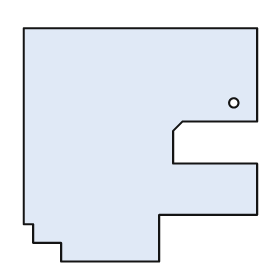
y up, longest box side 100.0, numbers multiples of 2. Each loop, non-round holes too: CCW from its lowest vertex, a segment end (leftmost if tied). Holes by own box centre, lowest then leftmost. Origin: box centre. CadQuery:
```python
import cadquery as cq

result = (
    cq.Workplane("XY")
    .moveTo(-34.0, -50.0)
    .lineTo(8.0, -50.0)
    .lineTo(8.0, -30.0)
    .lineTo(50.0, -30.0)
    .lineTo(50.0, -8.0)
    .lineTo(14.0, -8.0)
    .lineTo(14.0, 6.0)
    .lineTo(18.0, 10.0)
    .lineTo(50.0, 10.0)
    .lineTo(50.0, 50.0)
    .lineTo(-50.0, 50.0)
    .lineTo(-50.0, -34.0)
    .lineTo(-46.0, -34.0)
    .lineTo(-46.0, -42.0)
    .lineTo(-34.0, -42.0)
    .close()
    .moveTo(40.0, 18.0)
    .circle(2.0)
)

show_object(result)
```